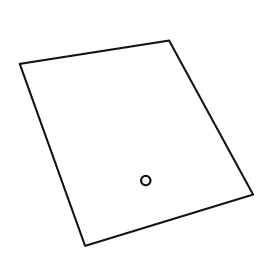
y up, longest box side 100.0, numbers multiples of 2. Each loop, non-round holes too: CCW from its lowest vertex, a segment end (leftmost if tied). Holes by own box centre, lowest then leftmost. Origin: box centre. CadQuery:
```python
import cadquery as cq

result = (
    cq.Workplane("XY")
    .moveTo(-22.0, -44.0)
    .lineTo(50.0, -22.0)
    .lineTo(14.0, 44.0)
    .lineTo(-50.0, 34.0)
    .close()
    .moveTo(4.0, -16.0)
    .circle(2.0)
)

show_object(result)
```